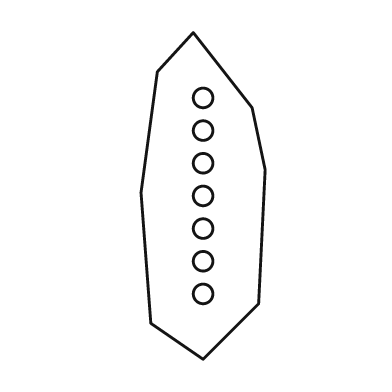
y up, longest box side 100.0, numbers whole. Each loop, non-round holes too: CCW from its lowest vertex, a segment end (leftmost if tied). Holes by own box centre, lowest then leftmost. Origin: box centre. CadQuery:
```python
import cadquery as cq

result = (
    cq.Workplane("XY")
    .moveTo(0.0, -50.0)
    .lineTo(17.0, -33.0)
    .lineTo(19.0, 8.0)
    .lineTo(15.0, 27.0)
    .lineTo(-3.0, 50.0)
    .lineTo(-14.0, 38.0)
    .lineTo(-19.0, 1.0)
    .lineTo(-16.0, -39.0)
    .close()
    .moveTo(0.0, -30.0)
    .circle(3.0)
    .moveTo(0.0, -20.0)
    .circle(3.0)
    .moveTo(0.0, -10.0)
    .circle(3.0)
    .moveTo(0.0, 0.0)
    .circle(3.0)
    .moveTo(0.0, 10.0)
    .circle(3.0)
    .moveTo(0.0, 20.0)
    .circle(3.0)
    .moveTo(0.0, 30.0)
    .circle(3.0)
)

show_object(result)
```